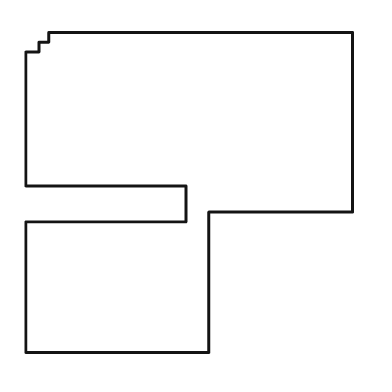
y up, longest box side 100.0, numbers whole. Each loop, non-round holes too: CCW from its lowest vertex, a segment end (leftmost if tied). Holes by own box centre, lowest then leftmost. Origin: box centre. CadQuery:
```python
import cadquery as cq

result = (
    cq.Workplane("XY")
    .moveTo(-50.0, -49.0)
    .lineTo(6.0, -49.0)
    .lineTo(6.0, -6.0)
    .lineTo(50.0, -6.0)
    .lineTo(50.0, 49.0)
    .lineTo(-43.0, 49.0)
    .lineTo(-43.0, 46.0)
    .lineTo(-46.0, 46.0)
    .lineTo(-46.0, 43.0)
    .lineTo(-50.0, 43.0)
    .lineTo(-50.0, 2.0)
    .lineTo(-1.0, 2.0)
    .lineTo(-1.0, -9.0)
    .lineTo(-50.0, -9.0)
    .close()
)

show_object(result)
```